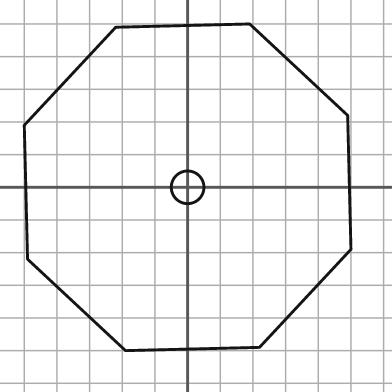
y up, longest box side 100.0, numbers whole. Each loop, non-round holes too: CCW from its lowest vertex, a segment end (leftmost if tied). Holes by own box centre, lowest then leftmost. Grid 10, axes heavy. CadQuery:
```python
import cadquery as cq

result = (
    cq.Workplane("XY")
    .moveTo(-19.0, -50.0)
    .lineTo(22.0, -49.0)
    .lineTo(50.0, -19.0)
    .lineTo(49.0, 22.0)
    .lineTo(19.0, 50.0)
    .lineTo(-22.0, 49.0)
    .lineTo(-50.0, 19.0)
    .lineTo(-49.0, -22.0)
    .close()
    .moveTo(0.0, 0.0)
    .circle(5.0)
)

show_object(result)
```